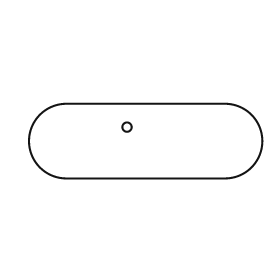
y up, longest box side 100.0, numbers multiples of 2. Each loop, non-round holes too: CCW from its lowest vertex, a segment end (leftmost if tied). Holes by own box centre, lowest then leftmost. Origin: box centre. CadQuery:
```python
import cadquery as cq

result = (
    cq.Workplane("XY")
    .moveTo(-34.0, -16.0)
    .lineTo(34.0, -16.0)
    .threePointArc((50.0, 0.0), (34.0, 16.0))
    .lineTo(-34.0, 16.0)
    .threePointArc((-50.0, 0.0), (-34.0, -16.0))
    .close()
    .moveTo(-8.0, 6.0)
    .circle(2.0)
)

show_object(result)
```